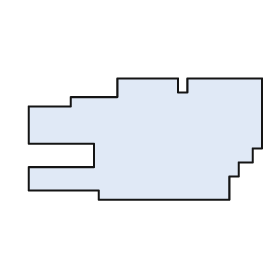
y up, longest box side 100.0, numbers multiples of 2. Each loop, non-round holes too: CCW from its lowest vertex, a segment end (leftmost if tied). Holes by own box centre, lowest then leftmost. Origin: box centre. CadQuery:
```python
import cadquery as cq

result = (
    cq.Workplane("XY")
    .moveTo(-20.0, -26.0)
    .lineTo(36.0, -26.0)
    .lineTo(36.0, -16.0)
    .lineTo(40.0, -16.0)
    .lineTo(40.0, -10.0)
    .lineTo(46.0, -10.0)
    .lineTo(46.0, -4.0)
    .lineTo(50.0, -4.0)
    .lineTo(50.0, 26.0)
    .lineTo(18.0, 26.0)
    .lineTo(18.0, 20.0)
    .lineTo(14.0, 20.0)
    .lineTo(14.0, 26.0)
    .lineTo(-12.0, 26.0)
    .lineTo(-12.0, 18.0)
    .lineTo(-32.0, 18.0)
    .lineTo(-32.0, 14.0)
    .lineTo(-50.0, 14.0)
    .lineTo(-50.0, -2.0)
    .lineTo(-22.0, -2.0)
    .lineTo(-22.0, -12.0)
    .lineTo(-50.0, -12.0)
    .lineTo(-50.0, -22.0)
    .lineTo(-20.0, -22.0)
    .close()
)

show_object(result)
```